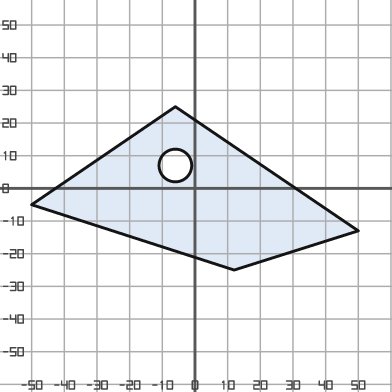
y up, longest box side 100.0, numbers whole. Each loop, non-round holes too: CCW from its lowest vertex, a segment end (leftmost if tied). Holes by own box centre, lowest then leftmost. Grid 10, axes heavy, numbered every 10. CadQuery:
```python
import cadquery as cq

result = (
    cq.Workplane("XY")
    .moveTo(12.0, -25.0)
    .lineTo(50.0, -13.0)
    .lineTo(-6.0, 25.0)
    .lineTo(-50.0, -5.0)
    .close()
    .moveTo(-6.0, 7.0)
    .circle(5.0)
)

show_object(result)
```